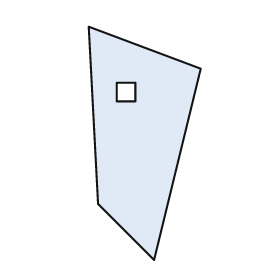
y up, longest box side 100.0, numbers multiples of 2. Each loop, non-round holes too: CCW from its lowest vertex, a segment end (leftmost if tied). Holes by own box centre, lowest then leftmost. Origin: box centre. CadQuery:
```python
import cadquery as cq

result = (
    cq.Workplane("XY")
    .moveTo(4.0, -50.0)
    .lineTo(24.0, 32.0)
    .lineTo(-24.0, 50.0)
    .lineTo(-20.0, -26.0)
    .close()
    .moveTo(-12.0, 18.0)
    .lineTo(-4.0, 18.0)
    .lineTo(-4.0, 26.0)
    .lineTo(-12.0, 26.0)
    .close()
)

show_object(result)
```